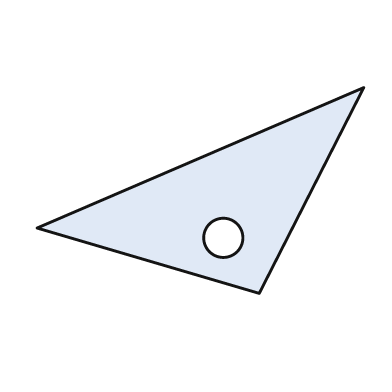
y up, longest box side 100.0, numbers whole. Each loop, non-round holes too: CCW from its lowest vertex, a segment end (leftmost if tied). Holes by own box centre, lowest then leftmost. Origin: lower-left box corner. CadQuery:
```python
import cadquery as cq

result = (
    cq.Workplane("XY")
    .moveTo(68.0, 0.0)
    .lineTo(100.0, 63.0)
    .lineTo(0.0, 20.0)
    .close()
    .moveTo(57.0, 17.0)
    .circle(6.0)
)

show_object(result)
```